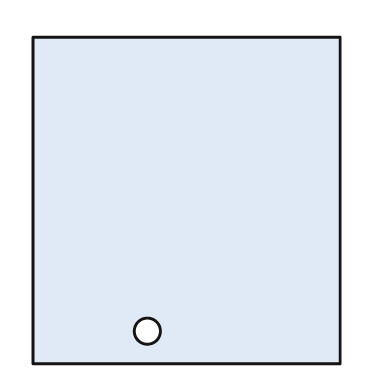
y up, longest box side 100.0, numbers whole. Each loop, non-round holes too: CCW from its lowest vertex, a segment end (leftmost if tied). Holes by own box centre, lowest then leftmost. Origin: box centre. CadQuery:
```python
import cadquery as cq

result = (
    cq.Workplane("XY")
    .moveTo(-47.0, -50.0)
    .lineTo(47.0, -50.0)
    .lineTo(47.0, 50.0)
    .lineTo(-47.0, 50.0)
    .close()
    .moveTo(-12.0, -40.0)
    .circle(4.0)
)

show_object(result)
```